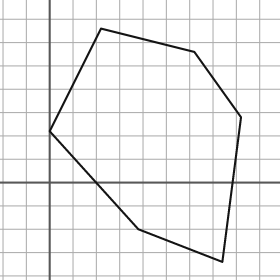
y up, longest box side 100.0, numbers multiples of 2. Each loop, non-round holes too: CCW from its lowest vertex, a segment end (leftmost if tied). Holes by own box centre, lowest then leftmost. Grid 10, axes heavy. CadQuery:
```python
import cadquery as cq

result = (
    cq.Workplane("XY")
    .moveTo(74.0, -34.0)
    .lineTo(82.0, 28.0)
    .lineTo(62.0, 56.0)
    .lineTo(22.0, 66.0)
    .lineTo(0.0, 22.0)
    .lineTo(38.0, -20.0)
    .close()
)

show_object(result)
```